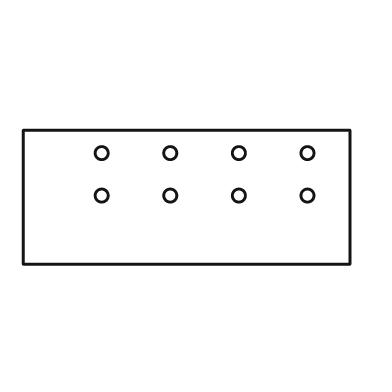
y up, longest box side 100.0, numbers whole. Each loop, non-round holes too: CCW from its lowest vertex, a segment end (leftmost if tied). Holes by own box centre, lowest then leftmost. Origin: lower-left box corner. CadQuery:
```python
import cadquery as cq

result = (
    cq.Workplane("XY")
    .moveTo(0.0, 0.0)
    .lineTo(100.0, 0.0)
    .lineTo(100.0, 41.0)
    .lineTo(0.0, 41.0)
    .close()
    .moveTo(24.0, 21.0)
    .circle(2.0)
    .moveTo(45.0, 21.0)
    .circle(2.0)
    .moveTo(66.0, 21.0)
    .circle(2.0)
    .moveTo(87.0, 21.0)
    .circle(2.0)
    .moveTo(24.0, 34.0)
    .circle(2.0)
    .moveTo(45.0, 34.0)
    .circle(2.0)
    .moveTo(66.0, 34.0)
    .circle(2.0)
    .moveTo(87.0, 34.0)
    .circle(2.0)
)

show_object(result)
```